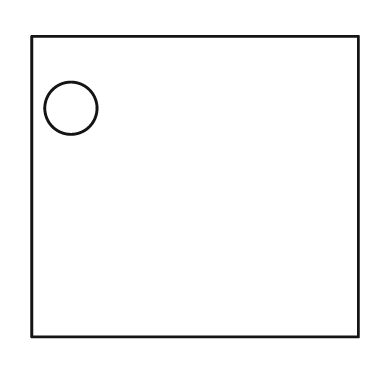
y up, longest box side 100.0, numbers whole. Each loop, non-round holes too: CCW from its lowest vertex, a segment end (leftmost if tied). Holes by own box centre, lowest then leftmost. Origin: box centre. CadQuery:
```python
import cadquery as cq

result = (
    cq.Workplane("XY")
    .moveTo(-50.0, -46.0)
    .lineTo(50.0, -46.0)
    .lineTo(50.0, 46.0)
    .lineTo(-50.0, 46.0)
    .close()
    .moveTo(-38.0, 24.0)
    .circle(8.0)
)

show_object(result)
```